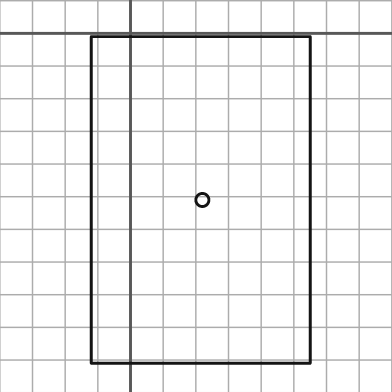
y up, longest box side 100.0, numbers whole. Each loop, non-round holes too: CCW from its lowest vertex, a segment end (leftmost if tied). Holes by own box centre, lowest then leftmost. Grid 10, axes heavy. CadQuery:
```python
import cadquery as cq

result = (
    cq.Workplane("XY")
    .moveTo(-12.0, -101.0)
    .lineTo(55.0, -101.0)
    .lineTo(55.0, -1.0)
    .lineTo(-12.0, -1.0)
    .close()
    .moveTo(22.0, -51.0)
    .circle(2.0)
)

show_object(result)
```